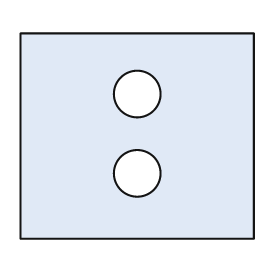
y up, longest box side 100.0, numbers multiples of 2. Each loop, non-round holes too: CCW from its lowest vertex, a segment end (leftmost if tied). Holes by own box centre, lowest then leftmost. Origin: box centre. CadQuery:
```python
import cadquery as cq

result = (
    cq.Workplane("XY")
    .moveTo(-50.0, -44.0)
    .lineTo(50.0, -44.0)
    .lineTo(50.0, 44.0)
    .lineTo(-50.0, 44.0)
    .close()
    .moveTo(0.0, -16.0)
    .circle(10.0)
    .moveTo(0.0, 18.0)
    .circle(10.0)
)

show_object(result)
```